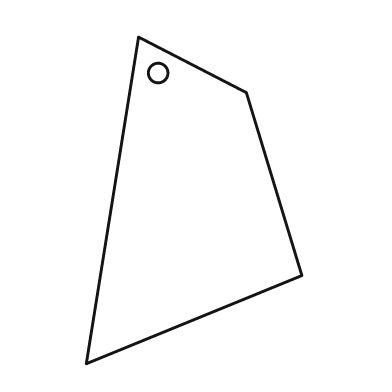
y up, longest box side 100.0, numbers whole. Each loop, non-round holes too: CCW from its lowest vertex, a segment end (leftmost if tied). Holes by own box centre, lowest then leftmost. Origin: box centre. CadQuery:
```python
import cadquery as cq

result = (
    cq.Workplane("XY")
    .moveTo(-33.0, -50.0)
    .lineTo(33.0, -23.0)
    .lineTo(16.0, 33.0)
    .lineTo(-17.0, 50.0)
    .close()
    .moveTo(-11.0, 39.0)
    .circle(3.0)
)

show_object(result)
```